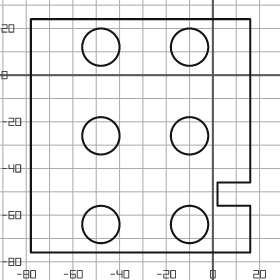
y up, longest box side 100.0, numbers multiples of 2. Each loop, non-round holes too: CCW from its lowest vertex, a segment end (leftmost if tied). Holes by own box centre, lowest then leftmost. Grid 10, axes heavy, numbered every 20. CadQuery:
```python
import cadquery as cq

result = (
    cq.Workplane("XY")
    .moveTo(-78.0, -76.0)
    .lineTo(16.0, -76.0)
    .lineTo(16.0, -56.0)
    .lineTo(2.0, -56.0)
    .lineTo(2.0, -46.0)
    .lineTo(16.0, -46.0)
    .lineTo(16.0, 24.0)
    .lineTo(-78.0, 24.0)
    .close()
    .moveTo(-48.0, -64.0)
    .circle(8.0)
    .moveTo(-10.0, -64.0)
    .circle(8.0)
    .moveTo(-48.0, -26.0)
    .circle(8.0)
    .moveTo(-10.0, -26.0)
    .circle(8.0)
    .moveTo(-48.0, 12.0)
    .circle(8.0)
    .moveTo(-10.0, 12.0)
    .circle(8.0)
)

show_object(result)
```